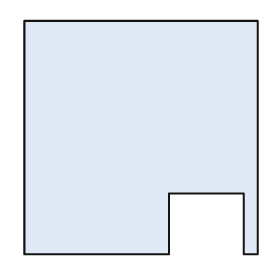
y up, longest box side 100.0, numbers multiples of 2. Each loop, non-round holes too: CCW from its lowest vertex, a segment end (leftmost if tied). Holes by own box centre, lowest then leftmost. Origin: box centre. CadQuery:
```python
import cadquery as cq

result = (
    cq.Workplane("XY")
    .moveTo(-50.0, -50.0)
    .lineTo(12.0, -50.0)
    .lineTo(12.0, -24.0)
    .lineTo(44.0, -24.0)
    .lineTo(44.0, -50.0)
    .lineTo(50.0, -50.0)
    .lineTo(50.0, 50.0)
    .lineTo(-50.0, 50.0)
    .close()
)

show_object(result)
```